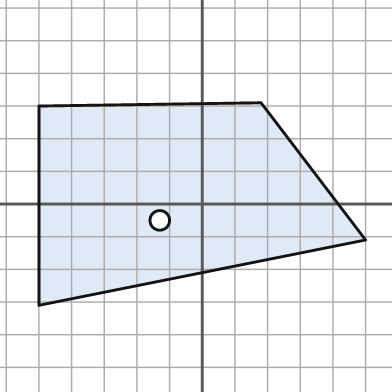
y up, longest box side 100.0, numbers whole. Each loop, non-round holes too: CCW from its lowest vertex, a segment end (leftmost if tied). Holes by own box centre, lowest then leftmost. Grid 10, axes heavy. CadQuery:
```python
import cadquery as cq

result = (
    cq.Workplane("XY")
    .moveTo(-50.0, -31.0)
    .lineTo(50.0, -11.0)
    .lineTo(18.0, 31.0)
    .lineTo(-50.0, 30.0)
    .close()
    .moveTo(-13.0, -5.0)
    .circle(3.0)
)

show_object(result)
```